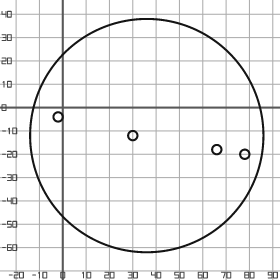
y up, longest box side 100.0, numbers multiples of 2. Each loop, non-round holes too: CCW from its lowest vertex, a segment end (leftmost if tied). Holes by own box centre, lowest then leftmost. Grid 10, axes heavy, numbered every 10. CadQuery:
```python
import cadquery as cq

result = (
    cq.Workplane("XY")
    .moveTo(36.0, -12.0)
    .circle(50.0)
    .moveTo(78.0, -20.0)
    .circle(2.0)
    .moveTo(66.0, -18.0)
    .circle(2.0)
    .moveTo(30.0, -12.0)
    .circle(2.0)
    .moveTo(-2.0, -4.0)
    .circle(2.0)
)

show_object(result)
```